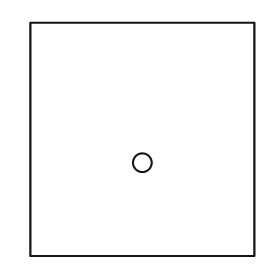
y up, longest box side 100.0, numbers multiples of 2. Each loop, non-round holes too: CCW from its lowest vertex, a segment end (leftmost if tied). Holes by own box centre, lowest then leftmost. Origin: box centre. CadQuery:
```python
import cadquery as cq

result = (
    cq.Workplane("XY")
    .moveTo(-48.0, -50.0)
    .lineTo(48.0, -50.0)
    .lineTo(48.0, 50.0)
    .lineTo(-48.0, 50.0)
    .close()
    .moveTo(0.0, -10.0)
    .circle(4.0)
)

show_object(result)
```